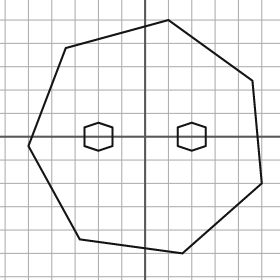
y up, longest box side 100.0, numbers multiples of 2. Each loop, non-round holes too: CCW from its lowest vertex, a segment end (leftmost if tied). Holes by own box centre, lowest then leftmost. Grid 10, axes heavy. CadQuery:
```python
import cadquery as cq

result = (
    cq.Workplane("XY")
    .moveTo(16.0, -50.0)
    .lineTo(50.0, -20.0)
    .lineTo(46.0, 24.0)
    .lineTo(10.0, 50.0)
    .lineTo(-34.0, 38.0)
    .lineTo(-50.0, -4.0)
    .lineTo(-28.0, -44.0)
    .close()
    .moveTo(-20.0, -6.0)
    .lineTo(-14.0, -4.0)
    .lineTo(-14.0, 4.0)
    .lineTo(-20.0, 6.0)
    .lineTo(-26.0, 4.0)
    .lineTo(-26.0, -4.0)
    .close()
    .moveTo(20.0, -6.0)
    .lineTo(26.0, -4.0)
    .lineTo(26.0, 4.0)
    .lineTo(20.0, 6.0)
    .lineTo(14.0, 4.0)
    .lineTo(14.0, -4.0)
    .close()
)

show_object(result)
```